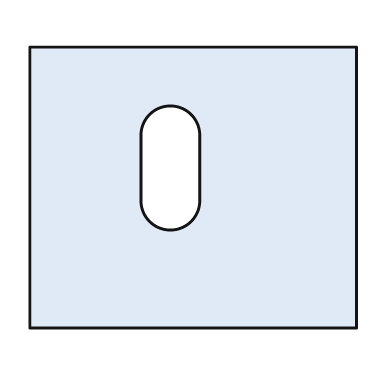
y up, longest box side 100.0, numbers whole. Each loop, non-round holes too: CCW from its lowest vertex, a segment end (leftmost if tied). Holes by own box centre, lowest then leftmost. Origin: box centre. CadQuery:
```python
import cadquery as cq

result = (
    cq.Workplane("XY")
    .moveTo(-50.0, -43.0)
    .lineTo(50.0, -43.0)
    .lineTo(50.0, 43.0)
    .lineTo(-50.0, 43.0)
    .close()
    .moveTo(-16.0, -4.0)
    .threePointArc((-7.0, -13.0), (2.0, -4.0))
    .lineTo(2.0, 16.0)
    .threePointArc((-7.0, 25.0), (-16.0, 16.0))
    .close()
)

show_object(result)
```